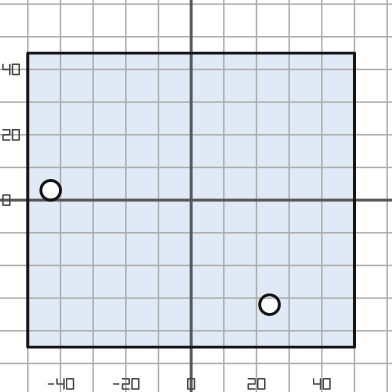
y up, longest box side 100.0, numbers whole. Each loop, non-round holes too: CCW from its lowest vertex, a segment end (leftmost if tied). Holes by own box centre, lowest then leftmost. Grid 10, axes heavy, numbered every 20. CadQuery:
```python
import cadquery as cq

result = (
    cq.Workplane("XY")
    .moveTo(-50.0, -45.0)
    .lineTo(50.0, -45.0)
    .lineTo(50.0, 45.0)
    .lineTo(-50.0, 45.0)
    .close()
    .moveTo(24.0, -32.0)
    .circle(3.0)
    .moveTo(-43.0, 3.0)
    .circle(3.0)
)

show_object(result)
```